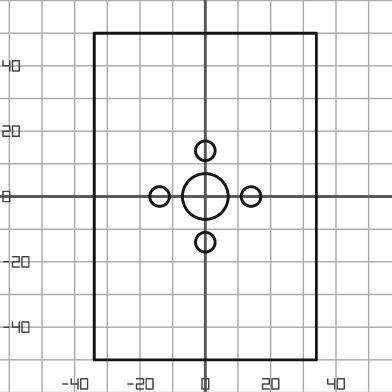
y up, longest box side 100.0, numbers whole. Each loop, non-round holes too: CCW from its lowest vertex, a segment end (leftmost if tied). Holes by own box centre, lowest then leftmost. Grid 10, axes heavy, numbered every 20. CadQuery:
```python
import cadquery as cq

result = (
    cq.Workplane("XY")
    .moveTo(-34.0, -50.0)
    .lineTo(34.0, -50.0)
    .lineTo(34.0, 50.0)
    .lineTo(-34.0, 50.0)
    .close()
    .moveTo(0.0, -14.0)
    .circle(3.0)
    .moveTo(-14.0, 0.0)
    .circle(3.0)
    .moveTo(0.0, 0.0)
    .circle(7.0)
    .moveTo(14.0, 0.0)
    .circle(3.0)
    .moveTo(0.0, 14.0)
    .circle(3.0)
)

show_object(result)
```